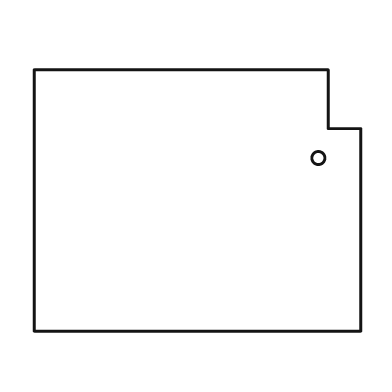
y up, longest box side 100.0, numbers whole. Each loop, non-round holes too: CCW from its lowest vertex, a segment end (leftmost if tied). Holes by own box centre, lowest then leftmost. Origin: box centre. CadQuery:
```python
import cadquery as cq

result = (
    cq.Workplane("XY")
    .moveTo(-50.0, -40.0)
    .lineTo(50.0, -40.0)
    .lineTo(50.0, 22.0)
    .lineTo(40.0, 22.0)
    .lineTo(40.0, 40.0)
    .lineTo(-50.0, 40.0)
    .close()
    .moveTo(37.0, 13.0)
    .circle(2.0)
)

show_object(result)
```